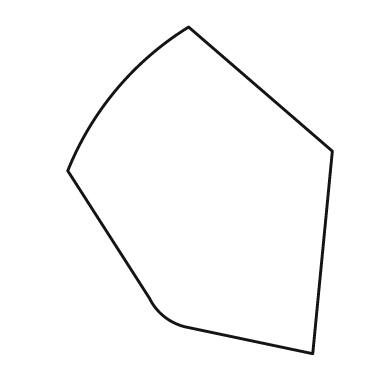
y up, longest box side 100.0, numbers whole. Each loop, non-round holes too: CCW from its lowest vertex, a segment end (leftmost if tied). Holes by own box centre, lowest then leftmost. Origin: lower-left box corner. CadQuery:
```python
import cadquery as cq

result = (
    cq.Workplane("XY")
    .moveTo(75.0, 0.0)
    .lineTo(81.0, 62.0)
    .lineTo(37.0, 100.0)
    .threePointArc((15.0, 81.0), (0.0, 56.0))
    .lineTo(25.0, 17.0)
    .threePointArc((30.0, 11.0), (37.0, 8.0))
    .close()
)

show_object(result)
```